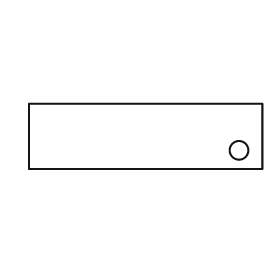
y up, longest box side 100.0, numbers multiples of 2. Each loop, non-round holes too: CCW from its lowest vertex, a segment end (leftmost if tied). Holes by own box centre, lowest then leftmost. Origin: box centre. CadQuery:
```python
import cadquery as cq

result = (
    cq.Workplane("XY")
    .moveTo(-50.0, -14.0)
    .lineTo(50.0, -14.0)
    .lineTo(50.0, 14.0)
    .lineTo(-50.0, 14.0)
    .close()
    .moveTo(40.0, -6.0)
    .circle(4.0)
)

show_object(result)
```